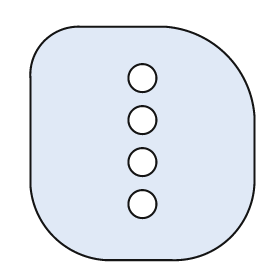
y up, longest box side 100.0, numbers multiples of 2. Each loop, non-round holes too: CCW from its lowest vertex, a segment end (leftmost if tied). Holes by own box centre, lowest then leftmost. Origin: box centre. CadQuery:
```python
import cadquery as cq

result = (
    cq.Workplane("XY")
    .moveTo(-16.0, -50.0)
    .lineTo(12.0, -50.0)
    .threePointArc((38.0, -40.0), (48.0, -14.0))
    .lineTo(48.0, 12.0)
    .threePointArc((36.0, 38.0), (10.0, 50.0))
    .lineTo(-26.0, 50.0)
    .threePointArc((-42.0, 44.0), (-48.0, 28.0))
    .lineTo(-48.0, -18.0)
    .threePointArc((-38.0, -40.0), (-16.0, -50.0))
    .close()
    .moveTo(0.0, -26.0)
    .circle(6.0)
    .moveTo(0.0, -8.0)
    .circle(6.0)
    .moveTo(0.0, 10.0)
    .circle(6.0)
    .moveTo(0.0, 28.0)
    .circle(6.0)
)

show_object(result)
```